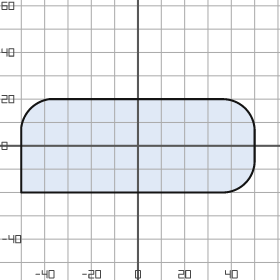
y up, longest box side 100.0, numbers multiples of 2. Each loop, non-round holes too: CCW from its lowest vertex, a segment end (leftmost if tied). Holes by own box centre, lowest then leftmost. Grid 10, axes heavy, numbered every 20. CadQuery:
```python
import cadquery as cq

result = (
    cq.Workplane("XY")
    .moveTo(-50.0, -20.0)
    .lineTo(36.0, -20.0)
    .threePointArc((46.0, -16.0), (50.0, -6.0))
    .lineTo(50.0, 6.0)
    .threePointArc((46.0, 16.0), (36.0, 20.0))
    .lineTo(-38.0, 20.0)
    .threePointArc((-46.0, 16.0), (-50.0, 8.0))
    .close()
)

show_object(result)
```